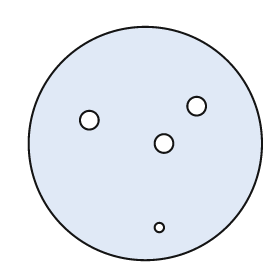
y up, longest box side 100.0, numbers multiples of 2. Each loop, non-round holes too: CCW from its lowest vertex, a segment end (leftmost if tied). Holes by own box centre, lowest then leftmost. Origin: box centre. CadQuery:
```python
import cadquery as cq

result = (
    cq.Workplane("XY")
    .moveTo(0.0, 0.0)
    .circle(50.0)
    .moveTo(6.0, -36.0)
    .circle(2.0)
    .moveTo(8.0, 0.0)
    .circle(4.0)
    .moveTo(-24.0, 10.0)
    .circle(4.0)
    .moveTo(22.0, 16.0)
    .circle(4.0)
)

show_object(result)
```